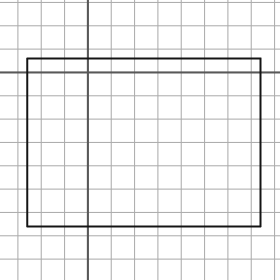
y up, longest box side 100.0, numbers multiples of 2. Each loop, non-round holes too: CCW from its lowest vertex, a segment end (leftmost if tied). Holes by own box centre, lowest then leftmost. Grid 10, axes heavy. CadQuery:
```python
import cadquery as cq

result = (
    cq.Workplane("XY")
    .moveTo(-26.0, -66.0)
    .lineTo(74.0, -66.0)
    .lineTo(74.0, 6.0)
    .lineTo(-26.0, 6.0)
    .close()
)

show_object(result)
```